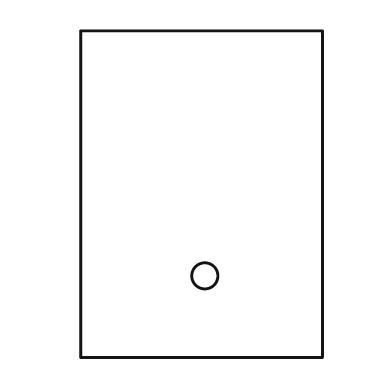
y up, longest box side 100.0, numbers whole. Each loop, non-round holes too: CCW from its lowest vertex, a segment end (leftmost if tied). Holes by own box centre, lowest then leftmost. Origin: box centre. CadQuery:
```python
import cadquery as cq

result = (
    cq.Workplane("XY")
    .moveTo(-37.0, -50.0)
    .lineTo(37.0, -50.0)
    .lineTo(37.0, 50.0)
    .lineTo(-37.0, 50.0)
    .close()
    .moveTo(1.0, -25.0)
    .circle(4.0)
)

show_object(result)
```